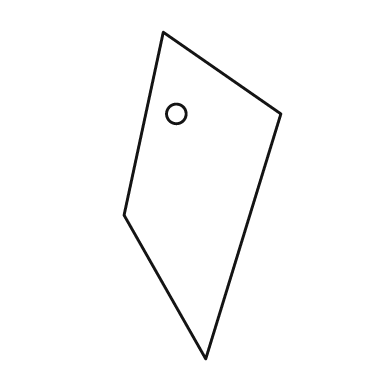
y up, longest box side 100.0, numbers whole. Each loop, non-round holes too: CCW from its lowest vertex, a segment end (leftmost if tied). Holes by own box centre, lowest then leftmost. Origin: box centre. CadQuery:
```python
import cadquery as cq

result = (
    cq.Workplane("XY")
    .moveTo(1.0, -50.0)
    .lineTo(24.0, 25.0)
    .lineTo(-12.0, 50.0)
    .lineTo(-24.0, -6.0)
    .close()
    .moveTo(-8.0, 25.0)
    .circle(3.0)
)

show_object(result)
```